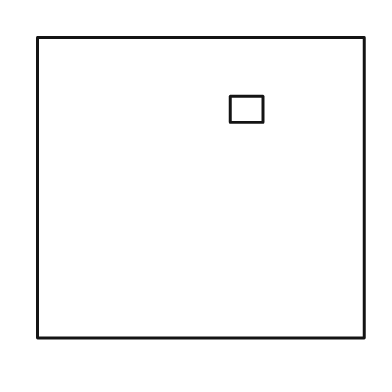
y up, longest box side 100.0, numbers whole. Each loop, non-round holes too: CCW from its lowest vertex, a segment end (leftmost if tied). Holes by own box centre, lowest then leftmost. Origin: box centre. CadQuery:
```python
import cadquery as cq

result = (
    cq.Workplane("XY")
    .moveTo(-50.0, -46.0)
    .lineTo(50.0, -46.0)
    .lineTo(50.0, 46.0)
    .lineTo(-50.0, 46.0)
    .close()
    .moveTo(9.0, 20.0)
    .lineTo(19.0, 20.0)
    .lineTo(19.0, 28.0)
    .lineTo(9.0, 28.0)
    .close()
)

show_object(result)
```